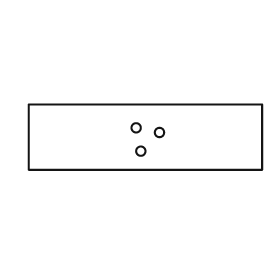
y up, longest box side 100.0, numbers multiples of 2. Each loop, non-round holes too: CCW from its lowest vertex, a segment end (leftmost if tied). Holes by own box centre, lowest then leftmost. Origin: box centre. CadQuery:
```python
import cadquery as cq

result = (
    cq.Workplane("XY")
    .moveTo(-50.0, -14.0)
    .lineTo(50.0, -14.0)
    .lineTo(50.0, 14.0)
    .lineTo(-50.0, 14.0)
    .close()
    .moveTo(-2.0, -6.0)
    .circle(2.0)
    .moveTo(6.0, 2.0)
    .circle(2.0)
    .moveTo(-4.0, 4.0)
    .circle(2.0)
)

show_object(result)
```